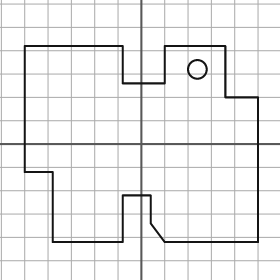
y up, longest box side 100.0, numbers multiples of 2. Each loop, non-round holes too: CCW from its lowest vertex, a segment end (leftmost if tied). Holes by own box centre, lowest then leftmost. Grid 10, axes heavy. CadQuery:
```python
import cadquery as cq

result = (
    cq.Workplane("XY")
    .moveTo(-38.0, -42.0)
    .lineTo(-8.0, -42.0)
    .lineTo(-8.0, -22.0)
    .lineTo(4.0, -22.0)
    .lineTo(4.0, -34.0)
    .lineTo(10.0, -42.0)
    .lineTo(50.0, -42.0)
    .lineTo(50.0, 20.0)
    .lineTo(36.0, 20.0)
    .lineTo(36.0, 42.0)
    .lineTo(10.0, 42.0)
    .lineTo(10.0, 26.0)
    .lineTo(-8.0, 26.0)
    .lineTo(-8.0, 42.0)
    .lineTo(-50.0, 42.0)
    .lineTo(-50.0, -12.0)
    .lineTo(-38.0, -12.0)
    .close()
    .moveTo(24.0, 32.0)
    .circle(4.0)
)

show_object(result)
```